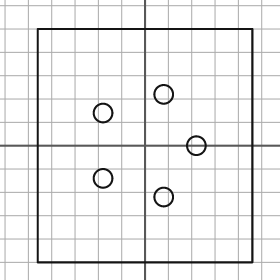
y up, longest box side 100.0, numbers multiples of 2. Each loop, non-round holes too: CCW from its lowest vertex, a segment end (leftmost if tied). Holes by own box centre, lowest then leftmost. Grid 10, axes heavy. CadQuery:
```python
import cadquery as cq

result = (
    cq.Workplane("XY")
    .moveTo(-46.0, -50.0)
    .lineTo(46.0, -50.0)
    .lineTo(46.0, 50.0)
    .lineTo(-46.0, 50.0)
    .close()
    .moveTo(8.0, -22.0)
    .circle(4.0)
    .moveTo(-18.0, -14.0)
    .circle(4.0)
    .moveTo(22.0, 0.0)
    .circle(4.0)
    .moveTo(-18.0, 14.0)
    .circle(4.0)
    .moveTo(8.0, 22.0)
    .circle(4.0)
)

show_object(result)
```